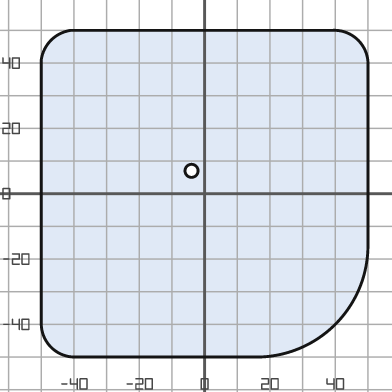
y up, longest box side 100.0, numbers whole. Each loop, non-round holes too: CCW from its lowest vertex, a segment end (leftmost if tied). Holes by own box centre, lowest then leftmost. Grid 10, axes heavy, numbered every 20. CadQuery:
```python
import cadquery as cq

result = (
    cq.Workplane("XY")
    .moveTo(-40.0, -50.0)
    .lineTo(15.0, -50.0)
    .threePointArc((40.0, -40.0), (50.0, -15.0))
    .lineTo(50.0, 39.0)
    .threePointArc((47.0, 47.0), (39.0, 50.0))
    .lineTo(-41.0, 50.0)
    .threePointArc((-47.0, 47.0), (-50.0, 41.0))
    .lineTo(-50.0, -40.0)
    .threePointArc((-47.0, -47.0), (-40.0, -50.0))
    .close()
    .moveTo(-4.0, 7.0)
    .circle(2.0)
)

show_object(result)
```